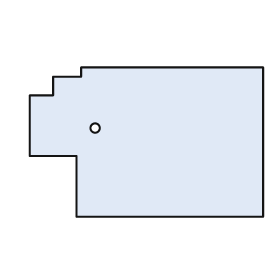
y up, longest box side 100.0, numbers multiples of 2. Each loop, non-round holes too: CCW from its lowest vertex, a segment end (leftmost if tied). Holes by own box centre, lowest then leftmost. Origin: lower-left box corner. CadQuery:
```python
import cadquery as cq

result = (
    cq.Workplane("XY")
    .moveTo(20.0, 0.0)
    .lineTo(100.0, 0.0)
    .lineTo(100.0, 64.0)
    .lineTo(22.0, 64.0)
    .lineTo(22.0, 60.0)
    .lineTo(10.0, 60.0)
    .lineTo(10.0, 52.0)
    .lineTo(0.0, 52.0)
    .lineTo(0.0, 26.0)
    .lineTo(20.0, 26.0)
    .close()
    .moveTo(28.0, 38.0)
    .circle(2.0)
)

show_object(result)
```